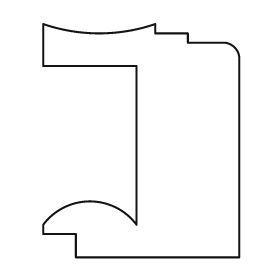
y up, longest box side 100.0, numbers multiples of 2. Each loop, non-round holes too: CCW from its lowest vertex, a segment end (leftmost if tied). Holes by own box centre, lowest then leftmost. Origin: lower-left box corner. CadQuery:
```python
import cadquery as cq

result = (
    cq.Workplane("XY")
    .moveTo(14.0, 0.0)
    .lineTo(84.0, 0.0)
    .lineTo(84.0, 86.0)
    .threePointArc((82.0, 90.0), (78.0, 92.0))
    .lineTo(62.0, 92.0)
    .lineTo(62.0, 96.0)
    .lineTo(48.0, 96.0)
    .lineTo(48.0, 100.0)
    .threePointArc((24.0, 96.0), (0.0, 100.0))
    .lineTo(0.0, 82.0)
    .lineTo(40.0, 82.0)
    .lineTo(40.0, 14.0)
    .threePointArc((20.0, 24.0), (0.0, 14.0))
    .lineTo(0.0, 10.0)
    .lineTo(14.0, 10.0)
    .close()
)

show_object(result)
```